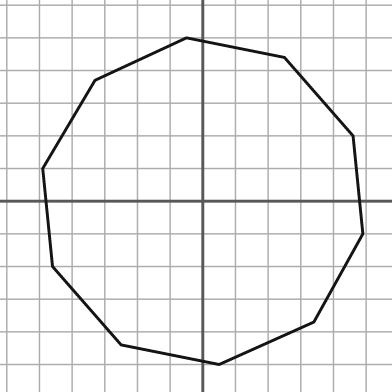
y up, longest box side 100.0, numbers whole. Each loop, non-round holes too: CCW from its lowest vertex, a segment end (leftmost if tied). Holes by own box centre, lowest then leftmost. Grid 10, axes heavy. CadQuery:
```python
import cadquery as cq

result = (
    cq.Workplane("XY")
    .moveTo(5.0, -50.0)
    .lineTo(34.0, -37.0)
    .lineTo(49.0, -10.0)
    .lineTo(46.0, 20.0)
    .lineTo(25.0, 44.0)
    .lineTo(-5.0, 50.0)
    .lineTo(-33.0, 37.0)
    .lineTo(-49.0, 10.0)
    .lineTo(-46.0, -20.0)
    .lineTo(-25.0, -44.0)
    .close()
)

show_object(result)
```